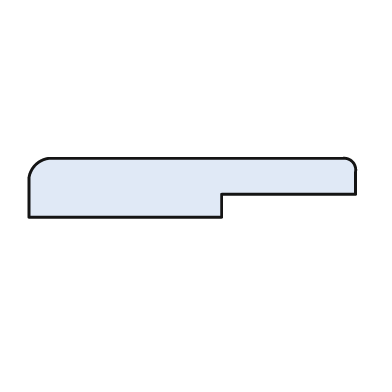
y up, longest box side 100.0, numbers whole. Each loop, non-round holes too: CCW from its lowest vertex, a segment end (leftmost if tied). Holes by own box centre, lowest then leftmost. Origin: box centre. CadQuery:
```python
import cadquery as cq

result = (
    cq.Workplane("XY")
    .moveTo(-50.0, -9.0)
    .lineTo(9.0, -9.0)
    .lineTo(9.0, -2.0)
    .lineTo(50.0, -2.0)
    .lineTo(50.0, 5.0)
    .threePointArc((49.0, 8.0), (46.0, 9.0))
    .lineTo(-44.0, 9.0)
    .threePointArc((-48.0, 7.0), (-50.0, 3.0))
    .close()
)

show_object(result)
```